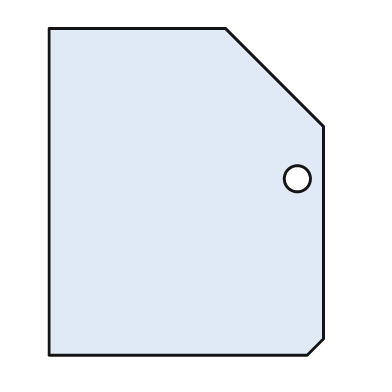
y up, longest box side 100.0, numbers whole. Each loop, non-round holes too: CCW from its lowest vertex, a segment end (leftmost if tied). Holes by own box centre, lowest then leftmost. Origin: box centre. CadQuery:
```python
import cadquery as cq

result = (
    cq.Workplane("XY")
    .moveTo(-42.0, -50.0)
    .lineTo(37.0, -50.0)
    .lineTo(42.0, -45.0)
    .lineTo(42.0, 20.0)
    .lineTo(12.0, 50.0)
    .lineTo(-42.0, 50.0)
    .close()
    .moveTo(34.0, 4.0)
    .circle(4.0)
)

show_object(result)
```